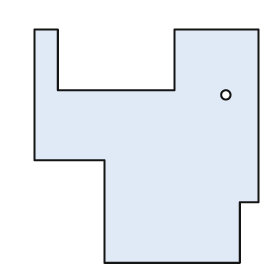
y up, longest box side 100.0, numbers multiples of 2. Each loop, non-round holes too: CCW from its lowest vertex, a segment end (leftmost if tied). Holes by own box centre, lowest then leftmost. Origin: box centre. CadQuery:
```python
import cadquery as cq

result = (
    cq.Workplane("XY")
    .moveTo(-18.0, -50.0)
    .lineTo(40.0, -50.0)
    .lineTo(40.0, -24.0)
    .lineTo(48.0, -24.0)
    .lineTo(48.0, 50.0)
    .lineTo(12.0, 50.0)
    .lineTo(12.0, 24.0)
    .lineTo(-38.0, 24.0)
    .lineTo(-38.0, 50.0)
    .lineTo(-48.0, 50.0)
    .lineTo(-48.0, -6.0)
    .lineTo(-18.0, -6.0)
    .close()
    .moveTo(34.0, 22.0)
    .circle(2.0)
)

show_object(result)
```